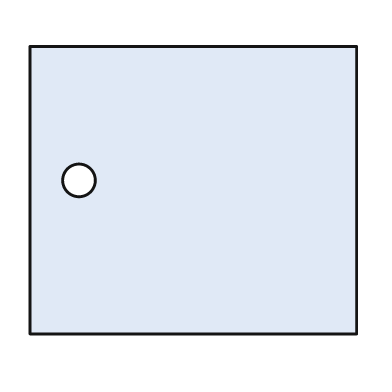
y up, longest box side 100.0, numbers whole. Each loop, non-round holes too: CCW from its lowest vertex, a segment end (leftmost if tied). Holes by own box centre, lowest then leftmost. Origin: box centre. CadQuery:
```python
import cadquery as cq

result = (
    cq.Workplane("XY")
    .moveTo(-50.0, -44.0)
    .lineTo(50.0, -44.0)
    .lineTo(50.0, 44.0)
    .lineTo(-50.0, 44.0)
    .close()
    .moveTo(-35.0, 3.0)
    .circle(5.0)
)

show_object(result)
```